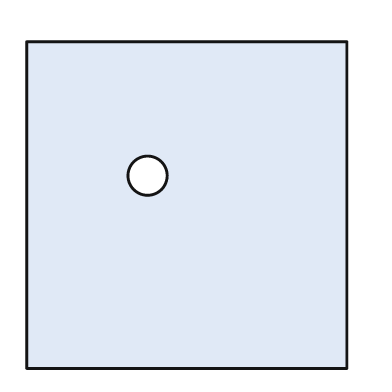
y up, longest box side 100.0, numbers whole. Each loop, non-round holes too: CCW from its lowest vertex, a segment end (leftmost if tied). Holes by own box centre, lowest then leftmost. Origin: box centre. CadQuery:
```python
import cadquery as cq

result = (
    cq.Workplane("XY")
    .moveTo(-49.0, -50.0)
    .lineTo(49.0, -50.0)
    .lineTo(49.0, 50.0)
    .lineTo(-49.0, 50.0)
    .close()
    .moveTo(-12.0, 9.0)
    .circle(6.0)
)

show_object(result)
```